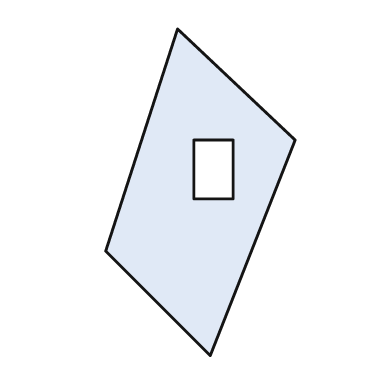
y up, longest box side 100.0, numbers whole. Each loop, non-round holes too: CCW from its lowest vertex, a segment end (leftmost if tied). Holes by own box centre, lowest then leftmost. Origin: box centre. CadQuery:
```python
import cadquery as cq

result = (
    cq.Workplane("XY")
    .moveTo(3.0, -50.0)
    .lineTo(29.0, 16.0)
    .lineTo(-7.0, 50.0)
    .lineTo(-29.0, -18.0)
    .close()
    .moveTo(-2.0, -2.0)
    .lineTo(10.0, -2.0)
    .lineTo(10.0, 16.0)
    .lineTo(-2.0, 16.0)
    .close()
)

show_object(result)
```